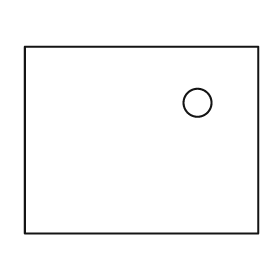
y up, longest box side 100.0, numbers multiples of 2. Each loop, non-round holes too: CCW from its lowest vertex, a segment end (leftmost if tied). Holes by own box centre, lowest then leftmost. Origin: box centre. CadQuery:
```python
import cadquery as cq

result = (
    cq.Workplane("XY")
    .moveTo(-50.0, -40.0)
    .lineTo(50.0, -40.0)
    .lineTo(50.0, 40.0)
    .lineTo(-50.0, 40.0)
    .close()
    .moveTo(24.0, 16.0)
    .circle(6.0)
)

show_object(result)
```